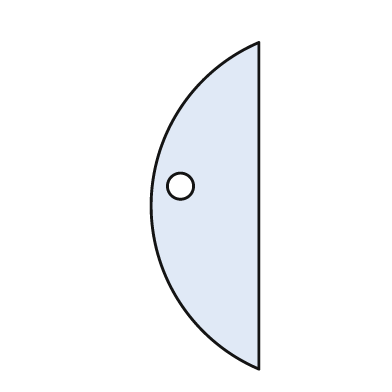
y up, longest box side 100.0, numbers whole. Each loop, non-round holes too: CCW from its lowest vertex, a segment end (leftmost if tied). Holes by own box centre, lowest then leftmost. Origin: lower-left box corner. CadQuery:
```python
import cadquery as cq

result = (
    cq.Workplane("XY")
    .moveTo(33.0, 0.0)
    .lineTo(33.0, 100.0)
    .threePointArc((0.0, 50.0), (33.0, 0.0))
    .close()
    .moveTo(9.0, 56.0)
    .circle(4.0)
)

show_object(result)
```